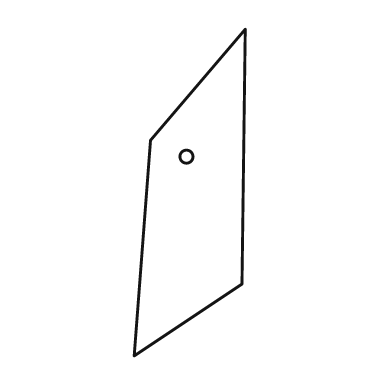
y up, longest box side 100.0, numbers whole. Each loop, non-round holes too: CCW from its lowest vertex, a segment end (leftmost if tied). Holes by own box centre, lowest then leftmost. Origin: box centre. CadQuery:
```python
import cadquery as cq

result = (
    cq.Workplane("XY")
    .moveTo(-17.0, -50.0)
    .lineTo(16.0, -28.0)
    .lineTo(17.0, 50.0)
    .lineTo(-12.0, 16.0)
    .close()
    .moveTo(-1.0, 11.0)
    .circle(2.0)
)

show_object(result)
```